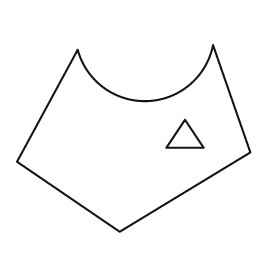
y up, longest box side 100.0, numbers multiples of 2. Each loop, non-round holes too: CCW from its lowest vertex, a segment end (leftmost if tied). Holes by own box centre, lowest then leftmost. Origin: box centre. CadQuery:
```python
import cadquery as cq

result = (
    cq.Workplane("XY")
    .moveTo(-6.0, -40.0)
    .lineTo(50.0, -6.0)
    .lineTo(34.0, 40.0)
    .threePointArc((6.0, 16.0), (-24.0, 38.0))
    .lineTo(-50.0, -10.0)
    .close()
    .moveTo(14.0, -4.0)
    .lineTo(30.0, -4.0)
    .lineTo(22.0, 8.0)
    .close()
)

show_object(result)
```